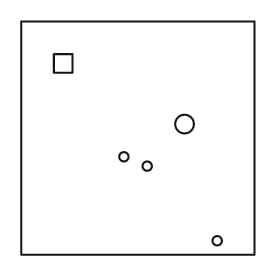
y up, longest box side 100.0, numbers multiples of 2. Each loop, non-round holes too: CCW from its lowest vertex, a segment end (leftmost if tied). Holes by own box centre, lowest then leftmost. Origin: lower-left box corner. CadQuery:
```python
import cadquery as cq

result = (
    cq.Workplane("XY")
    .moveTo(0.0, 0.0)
    .lineTo(100.0, 0.0)
    .lineTo(100.0, 100.0)
    .lineTo(0.0, 100.0)
    .close()
    .moveTo(84.0, 6.0)
    .circle(2.0)
    .moveTo(54.0, 38.0)
    .circle(2.0)
    .moveTo(44.0, 42.0)
    .circle(2.0)
    .moveTo(70.0, 56.0)
    .circle(4.0)
    .moveTo(14.0, 78.0)
    .lineTo(22.0, 78.0)
    .lineTo(22.0, 86.0)
    .lineTo(14.0, 86.0)
    .close()
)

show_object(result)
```